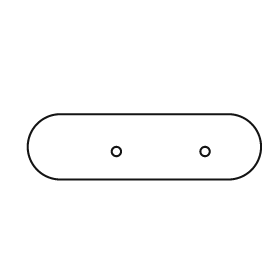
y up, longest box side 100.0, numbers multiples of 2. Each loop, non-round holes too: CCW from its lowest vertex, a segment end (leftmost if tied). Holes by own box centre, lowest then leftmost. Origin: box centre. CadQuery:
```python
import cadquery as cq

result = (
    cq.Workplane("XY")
    .moveTo(-36.0, -14.0)
    .lineTo(36.0, -14.0)
    .threePointArc((50.0, 0.0), (36.0, 14.0))
    .lineTo(-36.0, 14.0)
    .threePointArc((-50.0, 0.0), (-36.0, -14.0))
    .close()
    .moveTo(-12.0, -2.0)
    .circle(2.0)
    .moveTo(26.0, -2.0)
    .circle(2.0)
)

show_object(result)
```